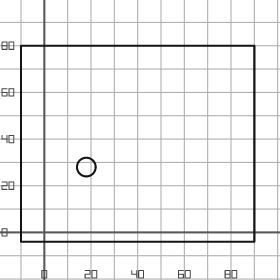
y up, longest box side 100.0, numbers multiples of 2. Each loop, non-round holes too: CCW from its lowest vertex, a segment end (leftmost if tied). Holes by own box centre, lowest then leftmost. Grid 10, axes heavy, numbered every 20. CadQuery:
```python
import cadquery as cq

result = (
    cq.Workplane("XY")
    .moveTo(-10.0, -4.0)
    .lineTo(90.0, -4.0)
    .lineTo(90.0, 80.0)
    .lineTo(-10.0, 80.0)
    .close()
    .moveTo(18.0, 28.0)
    .circle(4.0)
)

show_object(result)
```